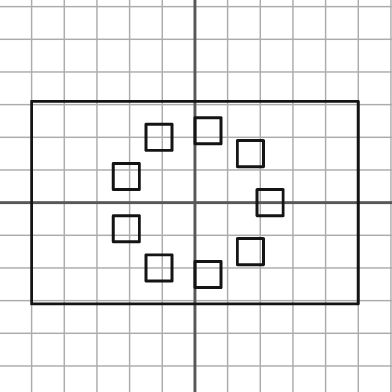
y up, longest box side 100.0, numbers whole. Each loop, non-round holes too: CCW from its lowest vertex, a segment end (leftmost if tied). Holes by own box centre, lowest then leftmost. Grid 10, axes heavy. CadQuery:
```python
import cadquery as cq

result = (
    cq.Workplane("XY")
    .moveTo(-50.0, -31.0)
    .lineTo(50.0, -31.0)
    .lineTo(50.0, 31.0)
    .lineTo(-50.0, 31.0)
    .close()
    .moveTo(0.0, -26.0)
    .lineTo(8.0, -26.0)
    .lineTo(8.0, -18.0)
    .lineTo(0.0, -18.0)
    .close()
    .moveTo(-15.0, -24.0)
    .lineTo(-7.0, -24.0)
    .lineTo(-7.0, -16.0)
    .lineTo(-15.0, -16.0)
    .close()
    .moveTo(13.0, -19.0)
    .lineTo(21.0, -19.0)
    .lineTo(21.0, -11.0)
    .lineTo(13.0, -11.0)
    .close()
    .moveTo(-25.0, -12.0)
    .lineTo(-17.0, -12.0)
    .lineTo(-17.0, -4.0)
    .lineTo(-25.0, -4.0)
    .close()
    .moveTo(19.0, -4.0)
    .lineTo(27.0, -4.0)
    .lineTo(27.0, 4.0)
    .lineTo(19.0, 4.0)
    .close()
    .moveTo(-25.0, 4.0)
    .lineTo(-17.0, 4.0)
    .lineTo(-17.0, 12.0)
    .lineTo(-25.0, 12.0)
    .close()
    .moveTo(13.0, 11.0)
    .lineTo(21.0, 11.0)
    .lineTo(21.0, 19.0)
    .lineTo(13.0, 19.0)
    .close()
    .moveTo(-15.0, 16.0)
    .lineTo(-7.0, 16.0)
    .lineTo(-7.0, 24.0)
    .lineTo(-15.0, 24.0)
    .close()
    .moveTo(0.0, 18.0)
    .lineTo(8.0, 18.0)
    .lineTo(8.0, 26.0)
    .lineTo(0.0, 26.0)
    .close()
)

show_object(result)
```